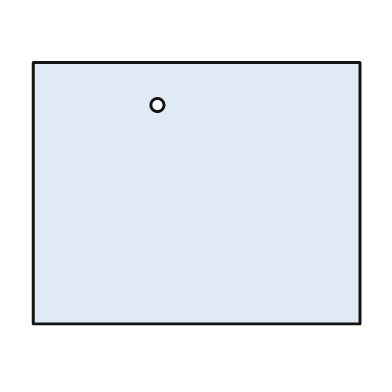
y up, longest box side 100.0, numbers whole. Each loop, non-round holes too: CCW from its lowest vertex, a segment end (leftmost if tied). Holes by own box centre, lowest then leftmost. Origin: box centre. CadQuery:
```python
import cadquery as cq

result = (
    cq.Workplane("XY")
    .moveTo(-50.0, -40.0)
    .lineTo(50.0, -40.0)
    .lineTo(50.0, 40.0)
    .lineTo(-50.0, 40.0)
    .close()
    .moveTo(-12.0, 27.0)
    .circle(2.0)
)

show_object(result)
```